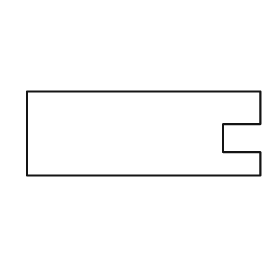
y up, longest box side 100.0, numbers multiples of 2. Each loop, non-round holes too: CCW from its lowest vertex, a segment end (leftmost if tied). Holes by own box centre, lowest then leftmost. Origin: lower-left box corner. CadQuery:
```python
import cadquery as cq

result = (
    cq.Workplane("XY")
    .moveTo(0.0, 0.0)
    .lineTo(100.0, 0.0)
    .lineTo(100.0, 10.0)
    .lineTo(84.0, 10.0)
    .lineTo(84.0, 22.0)
    .lineTo(100.0, 22.0)
    .lineTo(100.0, 36.0)
    .lineTo(0.0, 36.0)
    .close()
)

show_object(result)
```